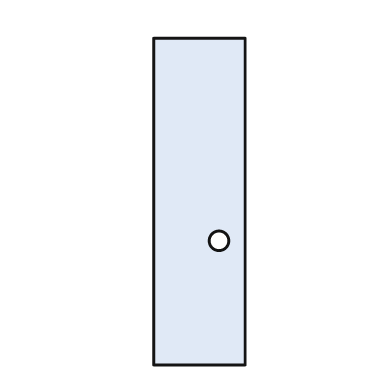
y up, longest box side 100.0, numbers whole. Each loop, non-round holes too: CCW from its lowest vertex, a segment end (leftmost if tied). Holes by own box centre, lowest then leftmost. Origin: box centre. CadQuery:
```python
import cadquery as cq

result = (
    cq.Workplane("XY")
    .moveTo(-14.0, -50.0)
    .lineTo(14.0, -50.0)
    .lineTo(14.0, 50.0)
    .lineTo(-14.0, 50.0)
    .close()
    .moveTo(6.0, -12.0)
    .circle(3.0)
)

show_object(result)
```